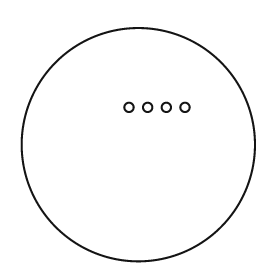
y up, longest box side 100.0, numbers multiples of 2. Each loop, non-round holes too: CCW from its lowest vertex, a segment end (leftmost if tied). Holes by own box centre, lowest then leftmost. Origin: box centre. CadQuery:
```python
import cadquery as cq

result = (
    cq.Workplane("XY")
    .moveTo(0.0, 0.0)
    .circle(50.0)
    .moveTo(-4.0, 16.0)
    .circle(2.0)
    .moveTo(4.0, 16.0)
    .circle(2.0)
    .moveTo(12.0, 16.0)
    .circle(2.0)
    .moveTo(20.0, 16.0)
    .circle(2.0)
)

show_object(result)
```